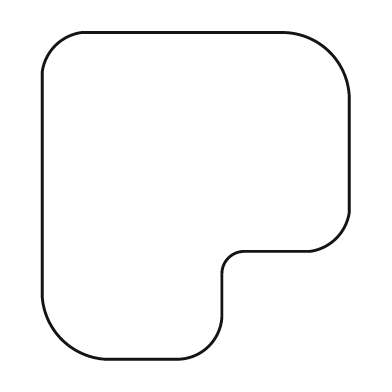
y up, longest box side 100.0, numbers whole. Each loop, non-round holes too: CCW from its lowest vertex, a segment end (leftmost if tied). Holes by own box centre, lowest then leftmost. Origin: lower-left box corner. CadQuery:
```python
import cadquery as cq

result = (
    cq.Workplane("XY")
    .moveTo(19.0, 0.0)
    .lineTo(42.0, 0.0)
    .threePointArc((51.0, 4.0), (55.0, 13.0))
    .lineTo(55.0, 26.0)
    .threePointArc((57.0, 31.0), (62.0, 33.0))
    .lineTo(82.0, 33.0)
    .threePointArc((90.0, 37.0), (94.0, 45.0))
    .lineTo(94.0, 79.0)
    .threePointArc((88.0, 94.0), (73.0, 100.0))
    .lineTo(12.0, 100.0)
    .threePointArc((4.0, 96.0), (0.0, 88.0))
    .lineTo(0.0, 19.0)
    .threePointArc((6.0, 6.0), (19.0, 0.0))
    .close()
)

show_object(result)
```